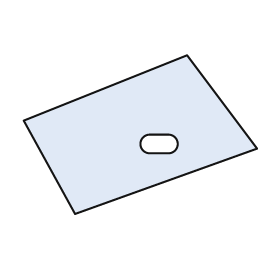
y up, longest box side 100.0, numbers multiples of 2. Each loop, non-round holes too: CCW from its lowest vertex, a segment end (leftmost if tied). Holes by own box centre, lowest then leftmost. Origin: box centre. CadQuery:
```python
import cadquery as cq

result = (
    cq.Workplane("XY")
    .moveTo(-28.0, -34.0)
    .lineTo(50.0, -6.0)
    .lineTo(20.0, 34.0)
    .lineTo(-50.0, 6.0)
    .close()
    .moveTo(4.0, -8.0)
    .lineTo(12.0, -8.0)
    .threePointArc((16.0, -4.0), (12.0, 0.0))
    .lineTo(4.0, 0.0)
    .threePointArc((0.0, -4.0), (4.0, -8.0))
    .close()
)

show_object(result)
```